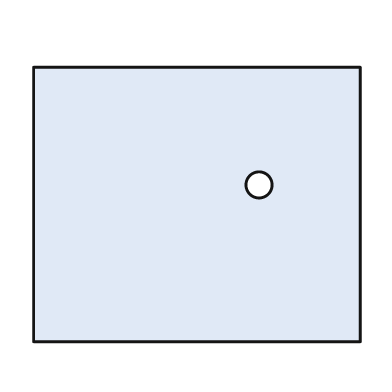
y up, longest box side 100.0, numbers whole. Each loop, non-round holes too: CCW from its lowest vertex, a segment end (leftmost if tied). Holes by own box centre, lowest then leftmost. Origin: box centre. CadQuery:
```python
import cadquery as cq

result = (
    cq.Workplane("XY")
    .moveTo(-50.0, -42.0)
    .lineTo(50.0, -42.0)
    .lineTo(50.0, 42.0)
    .lineTo(-50.0, 42.0)
    .close()
    .moveTo(19.0, 6.0)
    .circle(4.0)
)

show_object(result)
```